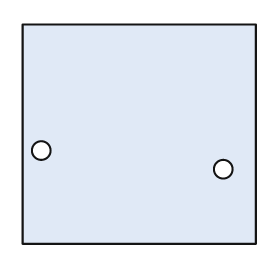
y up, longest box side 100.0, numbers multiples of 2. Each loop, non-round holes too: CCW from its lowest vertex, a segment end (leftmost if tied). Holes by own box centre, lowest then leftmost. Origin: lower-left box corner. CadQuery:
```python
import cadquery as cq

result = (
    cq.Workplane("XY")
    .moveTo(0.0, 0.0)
    .lineTo(100.0, 0.0)
    .lineTo(100.0, 94.0)
    .lineTo(0.0, 94.0)
    .close()
    .moveTo(86.0, 32.0)
    .circle(4.0)
    .moveTo(8.0, 40.0)
    .circle(4.0)
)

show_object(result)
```